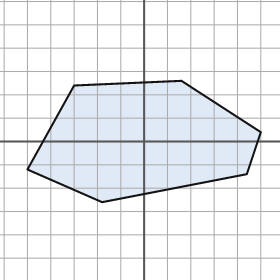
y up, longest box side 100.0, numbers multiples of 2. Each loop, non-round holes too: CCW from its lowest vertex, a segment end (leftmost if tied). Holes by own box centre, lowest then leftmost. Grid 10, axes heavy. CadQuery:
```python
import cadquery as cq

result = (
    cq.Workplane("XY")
    .moveTo(-18.0, -26.0)
    .lineTo(44.0, -14.0)
    .lineTo(50.0, 4.0)
    .lineTo(16.0, 26.0)
    .lineTo(-30.0, 24.0)
    .lineTo(-50.0, -12.0)
    .close()
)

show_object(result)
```